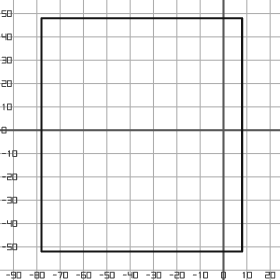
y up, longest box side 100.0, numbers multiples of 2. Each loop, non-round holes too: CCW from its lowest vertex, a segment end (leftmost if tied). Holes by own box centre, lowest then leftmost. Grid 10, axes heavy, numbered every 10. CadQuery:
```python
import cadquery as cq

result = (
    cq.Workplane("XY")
    .moveTo(-78.0, -52.0)
    .lineTo(8.0, -52.0)
    .lineTo(8.0, 48.0)
    .lineTo(-78.0, 48.0)
    .close()
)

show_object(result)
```